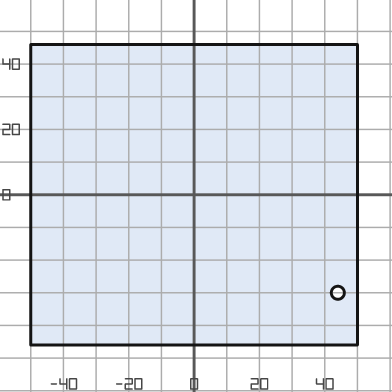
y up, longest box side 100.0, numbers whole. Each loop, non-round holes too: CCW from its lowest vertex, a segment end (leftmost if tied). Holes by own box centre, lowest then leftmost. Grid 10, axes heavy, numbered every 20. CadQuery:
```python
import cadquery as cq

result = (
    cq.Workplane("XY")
    .moveTo(-50.0, -46.0)
    .lineTo(50.0, -46.0)
    .lineTo(50.0, 46.0)
    .lineTo(-50.0, 46.0)
    .close()
    .moveTo(44.0, -30.0)
    .circle(2.0)
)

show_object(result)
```